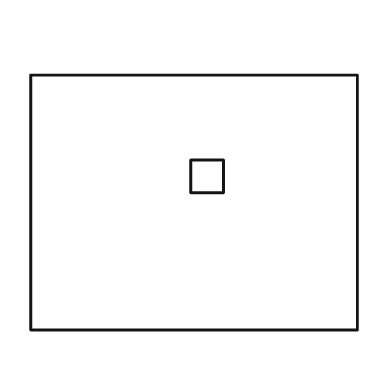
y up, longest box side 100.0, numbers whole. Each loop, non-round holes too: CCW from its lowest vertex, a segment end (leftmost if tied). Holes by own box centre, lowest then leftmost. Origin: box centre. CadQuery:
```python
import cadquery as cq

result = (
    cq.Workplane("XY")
    .moveTo(-50.0, -39.0)
    .lineTo(50.0, -39.0)
    .lineTo(50.0, 39.0)
    .lineTo(-50.0, 39.0)
    .close()
    .moveTo(-1.0, 3.0)
    .lineTo(9.0, 3.0)
    .lineTo(9.0, 13.0)
    .lineTo(-1.0, 13.0)
    .close()
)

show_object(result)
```